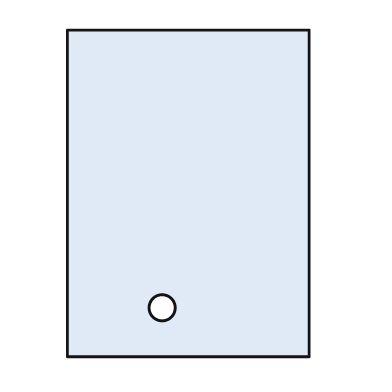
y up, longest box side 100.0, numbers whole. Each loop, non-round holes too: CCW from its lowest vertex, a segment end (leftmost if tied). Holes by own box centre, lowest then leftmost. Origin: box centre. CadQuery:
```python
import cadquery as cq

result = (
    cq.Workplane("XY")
    .moveTo(-37.0, -50.0)
    .lineTo(37.0, -50.0)
    .lineTo(37.0, 50.0)
    .lineTo(-37.0, 50.0)
    .close()
    .moveTo(-8.0, -35.0)
    .circle(4.0)
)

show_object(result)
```